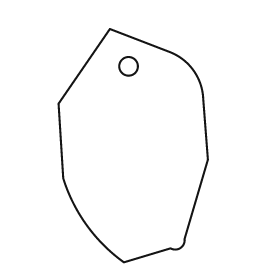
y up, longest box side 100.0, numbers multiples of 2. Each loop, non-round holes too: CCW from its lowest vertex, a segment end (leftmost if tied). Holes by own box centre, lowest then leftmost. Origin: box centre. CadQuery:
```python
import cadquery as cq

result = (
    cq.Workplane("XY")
    .moveTo(-4.0, -50.0)
    .lineTo(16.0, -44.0)
    .threePointArc((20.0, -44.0), (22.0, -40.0))
    .lineTo(32.0, -6.0)
    .lineTo(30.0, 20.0)
    .threePointArc((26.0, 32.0), (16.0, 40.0))
    .lineTo(-10.0, 50.0)
    .lineTo(-32.0, 18.0)
    .lineTo(-30.0, -14.0)
    .threePointArc((-20.0, -34.0), (-4.0, -50.0))
    .close()
    .moveTo(-2.0, 34.0)
    .circle(4.0)
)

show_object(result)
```